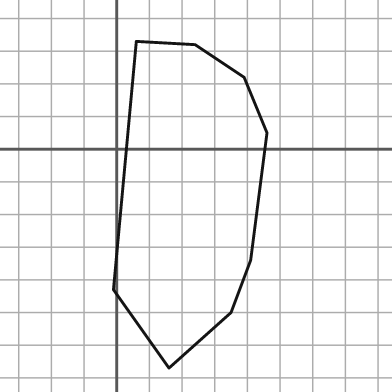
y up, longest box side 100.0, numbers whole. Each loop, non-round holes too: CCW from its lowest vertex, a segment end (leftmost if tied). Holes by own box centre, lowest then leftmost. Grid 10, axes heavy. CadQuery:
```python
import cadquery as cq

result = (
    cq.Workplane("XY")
    .moveTo(16.0, -67.0)
    .lineTo(35.0, -50.0)
    .lineTo(41.0, -34.0)
    .lineTo(46.0, 5.0)
    .lineTo(39.0, 22.0)
    .lineTo(24.0, 32.0)
    .lineTo(6.0, 33.0)
    .lineTo(-1.0, -43.0)
    .close()
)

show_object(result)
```